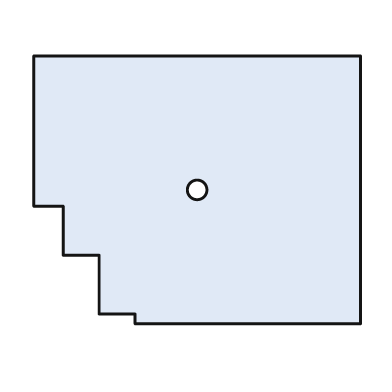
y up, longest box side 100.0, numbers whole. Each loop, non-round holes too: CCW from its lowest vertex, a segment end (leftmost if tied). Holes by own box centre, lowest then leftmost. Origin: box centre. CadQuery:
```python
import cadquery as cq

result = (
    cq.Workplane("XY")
    .moveTo(-19.0, -41.0)
    .lineTo(50.0, -41.0)
    .lineTo(50.0, 41.0)
    .lineTo(-50.0, 41.0)
    .lineTo(-50.0, -5.0)
    .lineTo(-41.0, -5.0)
    .lineTo(-41.0, -20.0)
    .lineTo(-30.0, -20.0)
    .lineTo(-30.0, -38.0)
    .lineTo(-19.0, -38.0)
    .close()
    .moveTo(0.0, 0.0)
    .circle(3.0)
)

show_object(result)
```